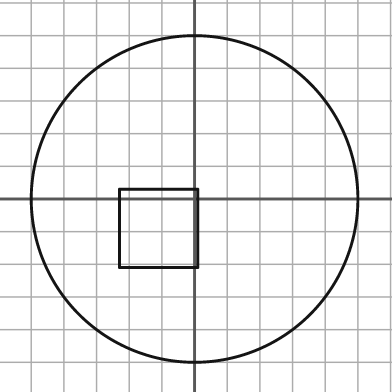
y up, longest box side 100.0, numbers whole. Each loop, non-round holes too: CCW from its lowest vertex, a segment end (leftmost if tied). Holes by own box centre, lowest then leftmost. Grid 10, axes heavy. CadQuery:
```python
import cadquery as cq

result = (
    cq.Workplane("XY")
    .moveTo(0.0, 0.0)
    .circle(50.0)
    .moveTo(-23.0, -21.0)
    .lineTo(1.0, -21.0)
    .lineTo(1.0, 3.0)
    .lineTo(-23.0, 3.0)
    .close()
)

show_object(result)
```